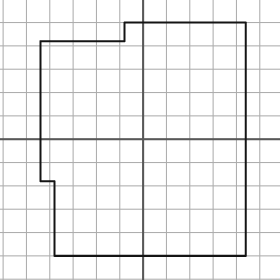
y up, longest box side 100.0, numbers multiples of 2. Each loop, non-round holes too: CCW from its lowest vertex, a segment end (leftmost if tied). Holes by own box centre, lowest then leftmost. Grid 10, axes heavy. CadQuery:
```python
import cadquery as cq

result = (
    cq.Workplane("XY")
    .moveTo(-38.0, -50.0)
    .lineTo(44.0, -50.0)
    .lineTo(44.0, 50.0)
    .lineTo(-8.0, 50.0)
    .lineTo(-8.0, 42.0)
    .lineTo(-44.0, 42.0)
    .lineTo(-44.0, -18.0)
    .lineTo(-38.0, -18.0)
    .close()
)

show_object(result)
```